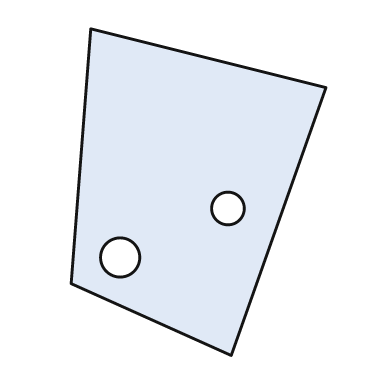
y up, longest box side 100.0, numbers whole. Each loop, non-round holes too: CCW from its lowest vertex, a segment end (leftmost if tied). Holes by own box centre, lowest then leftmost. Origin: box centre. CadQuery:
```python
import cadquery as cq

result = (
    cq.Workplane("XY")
    .moveTo(10.0, -50.0)
    .lineTo(39.0, 32.0)
    .lineTo(-33.0, 50.0)
    .lineTo(-39.0, -28.0)
    .close()
    .moveTo(-24.0, -20.0)
    .circle(6.0)
    .moveTo(9.0, -5.0)
    .circle(5.0)
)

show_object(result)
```